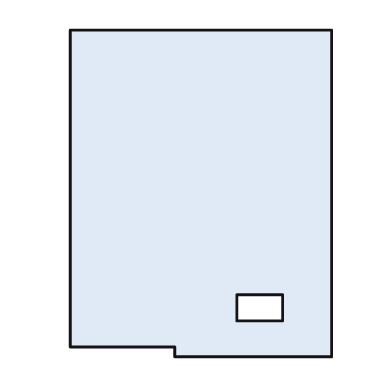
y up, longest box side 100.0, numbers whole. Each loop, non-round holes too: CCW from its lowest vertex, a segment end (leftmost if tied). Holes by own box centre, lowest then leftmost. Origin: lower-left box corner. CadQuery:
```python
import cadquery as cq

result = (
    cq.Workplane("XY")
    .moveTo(32.0, 0.0)
    .lineTo(80.0, 0.0)
    .lineTo(80.0, 100.0)
    .lineTo(0.0, 100.0)
    .lineTo(0.0, 3.0)
    .lineTo(32.0, 3.0)
    .close()
    .moveTo(51.0, 11.0)
    .lineTo(65.0, 11.0)
    .lineTo(65.0, 19.0)
    .lineTo(51.0, 19.0)
    .close()
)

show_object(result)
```